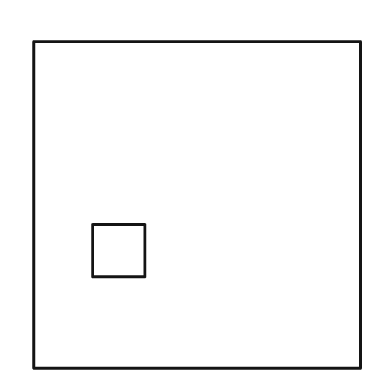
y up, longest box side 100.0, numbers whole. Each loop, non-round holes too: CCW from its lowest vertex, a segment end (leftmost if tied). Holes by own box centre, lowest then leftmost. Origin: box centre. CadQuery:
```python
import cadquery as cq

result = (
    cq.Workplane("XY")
    .moveTo(-50.0, -50.0)
    .lineTo(50.0, -50.0)
    .lineTo(50.0, 50.0)
    .lineTo(-50.0, 50.0)
    .close()
    .moveTo(-32.0, -22.0)
    .lineTo(-16.0, -22.0)
    .lineTo(-16.0, -6.0)
    .lineTo(-32.0, -6.0)
    .close()
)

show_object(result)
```